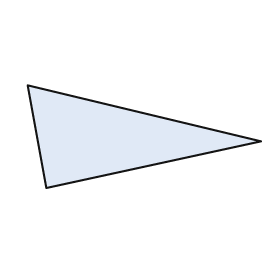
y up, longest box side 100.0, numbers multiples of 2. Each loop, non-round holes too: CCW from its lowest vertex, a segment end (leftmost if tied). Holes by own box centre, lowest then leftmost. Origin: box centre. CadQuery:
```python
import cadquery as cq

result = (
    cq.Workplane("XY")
    .moveTo(-42.0, -22.0)
    .lineTo(50.0, -2.0)
    .lineTo(-50.0, 22.0)
    .close()
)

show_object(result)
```